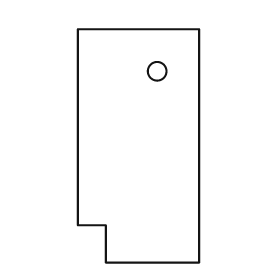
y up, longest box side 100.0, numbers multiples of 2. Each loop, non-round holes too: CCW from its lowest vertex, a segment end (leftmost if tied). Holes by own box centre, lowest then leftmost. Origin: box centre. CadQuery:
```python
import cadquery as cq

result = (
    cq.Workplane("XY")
    .moveTo(-14.0, -50.0)
    .lineTo(26.0, -50.0)
    .lineTo(26.0, 50.0)
    .lineTo(-26.0, 50.0)
    .lineTo(-26.0, -34.0)
    .lineTo(-14.0, -34.0)
    .close()
    .moveTo(8.0, 32.0)
    .circle(4.0)
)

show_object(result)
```